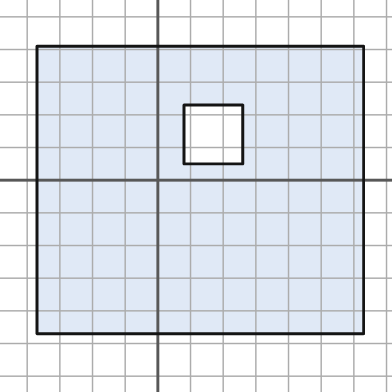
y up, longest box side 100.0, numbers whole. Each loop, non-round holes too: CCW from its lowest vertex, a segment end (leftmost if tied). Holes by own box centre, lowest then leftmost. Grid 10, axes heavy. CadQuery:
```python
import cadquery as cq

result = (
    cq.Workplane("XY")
    .moveTo(-37.0, -47.0)
    .lineTo(63.0, -47.0)
    .lineTo(63.0, 41.0)
    .lineTo(-37.0, 41.0)
    .close()
    .moveTo(8.0, 5.0)
    .lineTo(26.0, 5.0)
    .lineTo(26.0, 23.0)
    .lineTo(8.0, 23.0)
    .close()
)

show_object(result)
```